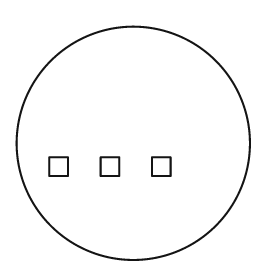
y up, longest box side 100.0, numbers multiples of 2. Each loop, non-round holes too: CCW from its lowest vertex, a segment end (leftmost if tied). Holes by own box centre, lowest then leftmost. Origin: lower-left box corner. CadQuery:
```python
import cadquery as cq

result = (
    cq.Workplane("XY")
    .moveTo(50.0, 50.0)
    .circle(50.0)
    .moveTo(14.0, 36.0)
    .lineTo(22.0, 36.0)
    .lineTo(22.0, 44.0)
    .lineTo(14.0, 44.0)
    .close()
    .moveTo(36.0, 36.0)
    .lineTo(44.0, 36.0)
    .lineTo(44.0, 44.0)
    .lineTo(36.0, 44.0)
    .close()
    .moveTo(58.0, 36.0)
    .lineTo(66.0, 36.0)
    .lineTo(66.0, 44.0)
    .lineTo(58.0, 44.0)
    .close()
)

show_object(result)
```